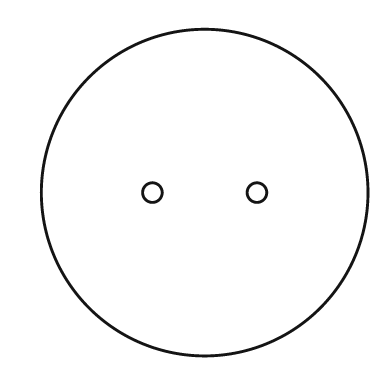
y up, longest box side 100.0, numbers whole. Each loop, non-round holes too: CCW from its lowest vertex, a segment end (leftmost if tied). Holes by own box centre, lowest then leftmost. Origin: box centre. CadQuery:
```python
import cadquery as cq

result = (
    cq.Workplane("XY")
    .moveTo(0.0, 0.0)
    .circle(50.0)
    .moveTo(-16.0, 0.0)
    .circle(3.0)
    .moveTo(16.0, 0.0)
    .circle(3.0)
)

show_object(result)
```